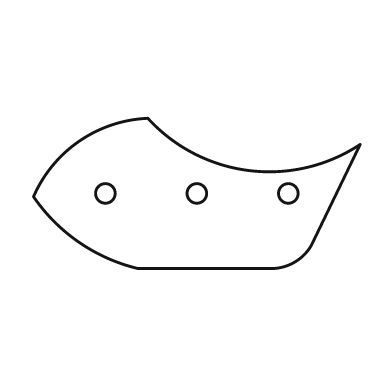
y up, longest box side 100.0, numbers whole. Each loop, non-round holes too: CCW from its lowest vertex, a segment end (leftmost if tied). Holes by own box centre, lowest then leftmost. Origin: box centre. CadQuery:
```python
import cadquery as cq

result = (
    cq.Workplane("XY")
    .moveTo(-18.0, -23.0)
    .lineTo(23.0, -23.0)
    .threePointArc((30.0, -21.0), (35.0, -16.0))
    .lineTo(50.0, 15.0)
    .threePointArc((16.0, 7.0), (-15.0, 23.0))
    .threePointArc((-36.0, 16.0), (-50.0, -1.0))
    .threePointArc((-36.0, -15.0), (-18.0, -23.0))
    .close()
    .moveTo(-28.0, 0.0)
    .circle(3.0)
    .moveTo(0.0, 0.0)
    .circle(3.0)
    .moveTo(28.0, 0.0)
    .circle(3.0)
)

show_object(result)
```